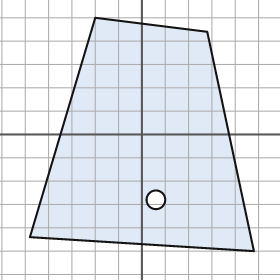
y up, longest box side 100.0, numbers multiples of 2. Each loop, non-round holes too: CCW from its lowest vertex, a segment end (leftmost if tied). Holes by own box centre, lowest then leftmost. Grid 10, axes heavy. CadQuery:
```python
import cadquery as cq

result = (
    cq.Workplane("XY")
    .moveTo(48.0, -50.0)
    .lineTo(28.0, 44.0)
    .lineTo(-20.0, 50.0)
    .lineTo(-48.0, -44.0)
    .close()
    .moveTo(6.0, -28.0)
    .circle(4.0)
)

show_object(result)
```